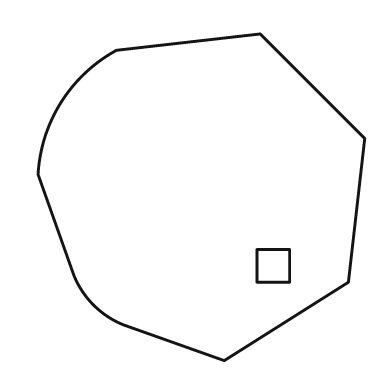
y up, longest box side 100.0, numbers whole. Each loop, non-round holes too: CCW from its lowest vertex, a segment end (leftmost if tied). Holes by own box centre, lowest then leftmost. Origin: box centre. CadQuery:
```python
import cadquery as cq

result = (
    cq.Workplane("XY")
    .moveTo(7.0, -50.0)
    .lineTo(45.0, -26.0)
    .lineTo(50.0, 18.0)
    .lineTo(18.0, 50.0)
    .lineTo(-26.0, 45.0)
    .threePointArc((-43.0, 29.0), (-50.0, 7.0))
    .lineTo(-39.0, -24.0)
    .threePointArc((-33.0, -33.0), (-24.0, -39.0))
    .close()
    .moveTo(17.0, -26.0)
    .lineTo(27.0, -26.0)
    .lineTo(27.0, -16.0)
    .lineTo(17.0, -16.0)
    .close()
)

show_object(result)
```